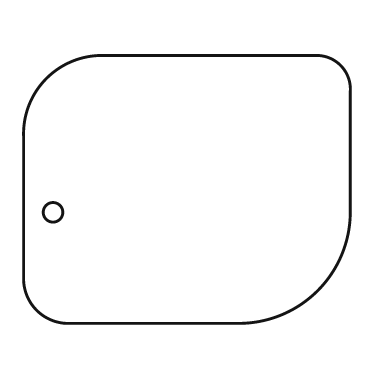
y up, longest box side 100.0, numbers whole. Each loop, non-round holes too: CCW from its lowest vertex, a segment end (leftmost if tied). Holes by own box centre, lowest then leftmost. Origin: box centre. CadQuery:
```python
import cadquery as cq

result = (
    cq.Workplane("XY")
    .moveTo(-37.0, -41.0)
    .lineTo(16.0, -41.0)
    .threePointArc((40.0, -31.0), (50.0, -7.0))
    .lineTo(50.0, 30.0)
    .threePointArc((47.0, 38.0), (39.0, 41.0))
    .lineTo(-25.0, 41.0)
    .threePointArc((-43.0, 34.0), (-50.0, 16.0))
    .lineTo(-50.0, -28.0)
    .threePointArc((-46.0, -37.0), (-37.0, -41.0))
    .close()
    .moveTo(-41.0, -7.0)
    .circle(3.0)
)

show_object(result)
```